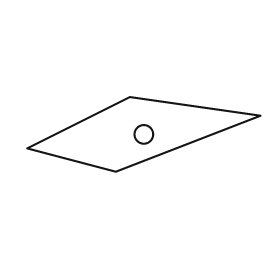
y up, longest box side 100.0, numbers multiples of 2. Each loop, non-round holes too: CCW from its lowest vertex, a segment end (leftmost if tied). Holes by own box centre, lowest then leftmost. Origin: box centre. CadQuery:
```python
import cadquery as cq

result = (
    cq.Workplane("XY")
    .moveTo(-12.0, -16.0)
    .lineTo(50.0, 8.0)
    .lineTo(-6.0, 16.0)
    .lineTo(-50.0, -6.0)
    .close()
    .moveTo(0.0, 0.0)
    .circle(4.0)
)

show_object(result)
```